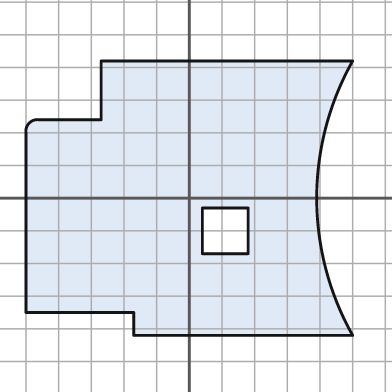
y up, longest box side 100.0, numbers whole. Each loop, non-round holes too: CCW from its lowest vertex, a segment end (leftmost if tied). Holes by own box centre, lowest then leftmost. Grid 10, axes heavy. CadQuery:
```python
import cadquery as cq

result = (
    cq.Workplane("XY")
    .moveTo(-17.0, -42.0)
    .lineTo(50.0, -42.0)
    .threePointArc((39.0, 0.0), (50.0, 42.0))
    .lineTo(-27.0, 42.0)
    .lineTo(-27.0, 24.0)
    .lineTo(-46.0, 24.0)
    .threePointArc((-49.0, 23.0), (-50.0, 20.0))
    .lineTo(-50.0, -35.0)
    .lineTo(-17.0, -35.0)
    .close()
    .moveTo(4.0, -17.0)
    .lineTo(18.0, -17.0)
    .lineTo(18.0, -3.0)
    .lineTo(4.0, -3.0)
    .close()
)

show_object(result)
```